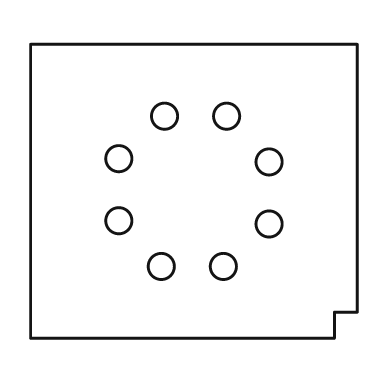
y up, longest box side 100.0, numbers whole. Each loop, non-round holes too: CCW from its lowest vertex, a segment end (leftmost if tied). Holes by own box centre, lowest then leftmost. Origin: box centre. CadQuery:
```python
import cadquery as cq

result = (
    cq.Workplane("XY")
    .moveTo(-50.0, -45.0)
    .lineTo(43.0, -45.0)
    .lineTo(43.0, -37.0)
    .lineTo(50.0, -37.0)
    .lineTo(50.0, 45.0)
    .lineTo(-50.0, 45.0)
    .close()
    .moveTo(-10.0, -23.0)
    .circle(4.0)
    .moveTo(9.0, -23.0)
    .circle(4.0)
    .moveTo(23.0, -10.0)
    .circle(4.0)
    .moveTo(-23.0, -9.0)
    .circle(4.0)
    .moveTo(23.0, 9.0)
    .circle(4.0)
    .moveTo(-23.0, 10.0)
    .circle(4.0)
    .moveTo(-9.0, 23.0)
    .circle(4.0)
    .moveTo(10.0, 23.0)
    .circle(4.0)
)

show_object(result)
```